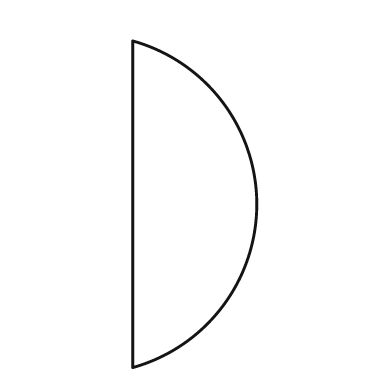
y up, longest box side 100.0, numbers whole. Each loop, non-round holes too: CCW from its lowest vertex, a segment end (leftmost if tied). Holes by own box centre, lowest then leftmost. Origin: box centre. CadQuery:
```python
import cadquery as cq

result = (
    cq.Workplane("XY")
    .moveTo(-19.0, -50.0)
    .threePointArc((19.0, 0.0), (-19.0, 50.0))
    .close()
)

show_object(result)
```